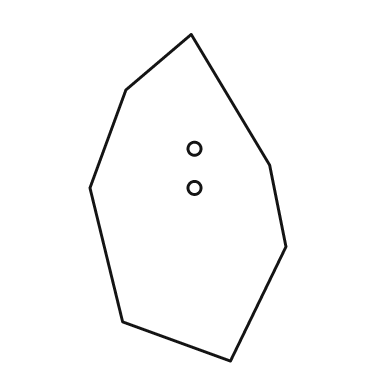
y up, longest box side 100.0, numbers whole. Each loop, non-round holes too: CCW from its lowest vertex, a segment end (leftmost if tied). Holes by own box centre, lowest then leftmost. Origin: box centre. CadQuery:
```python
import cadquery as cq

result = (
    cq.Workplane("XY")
    .moveTo(13.0, -50.0)
    .lineTo(30.0, -15.0)
    .lineTo(25.0, 10.0)
    .lineTo(1.0, 50.0)
    .lineTo(-19.0, 33.0)
    .lineTo(-30.0, 3.0)
    .lineTo(-20.0, -38.0)
    .close()
    .moveTo(2.0, 3.0)
    .circle(2.0)
    .moveTo(2.0, 15.0)
    .circle(2.0)
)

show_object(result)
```